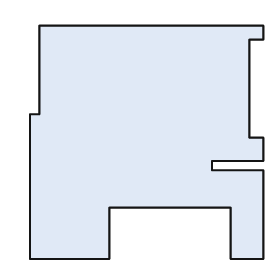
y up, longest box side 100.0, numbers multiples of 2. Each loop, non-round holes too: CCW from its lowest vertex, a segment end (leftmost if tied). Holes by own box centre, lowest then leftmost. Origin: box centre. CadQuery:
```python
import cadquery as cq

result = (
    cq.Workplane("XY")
    .moveTo(-50.0, -50.0)
    .lineTo(-16.0, -50.0)
    .lineTo(-16.0, -28.0)
    .lineTo(36.0, -28.0)
    .lineTo(36.0, -50.0)
    .lineTo(50.0, -50.0)
    .lineTo(50.0, -12.0)
    .lineTo(28.0, -12.0)
    .lineTo(28.0, -8.0)
    .lineTo(50.0, -8.0)
    .lineTo(50.0, 2.0)
    .lineTo(44.0, 2.0)
    .lineTo(44.0, 44.0)
    .lineTo(50.0, 44.0)
    .lineTo(50.0, 50.0)
    .lineTo(-46.0, 50.0)
    .lineTo(-46.0, 12.0)
    .lineTo(-50.0, 12.0)
    .close()
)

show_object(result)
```